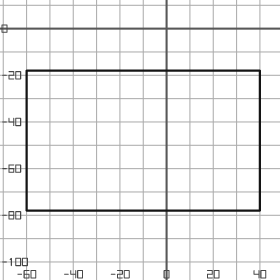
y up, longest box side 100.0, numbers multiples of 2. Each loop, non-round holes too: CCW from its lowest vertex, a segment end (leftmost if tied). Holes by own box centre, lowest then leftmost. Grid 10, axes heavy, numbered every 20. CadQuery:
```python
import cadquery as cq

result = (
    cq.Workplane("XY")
    .moveTo(-60.0, -78.0)
    .lineTo(40.0, -78.0)
    .lineTo(40.0, -18.0)
    .lineTo(-60.0, -18.0)
    .close()
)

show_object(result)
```